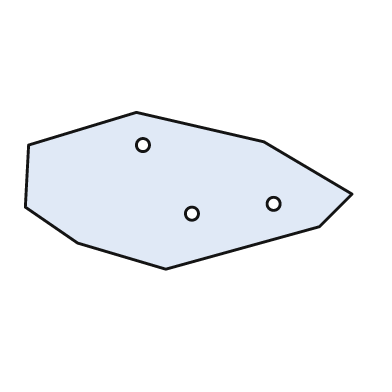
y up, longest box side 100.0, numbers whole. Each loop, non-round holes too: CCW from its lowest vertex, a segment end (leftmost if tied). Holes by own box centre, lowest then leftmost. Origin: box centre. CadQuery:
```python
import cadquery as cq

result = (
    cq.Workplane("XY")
    .moveTo(-7.0, -24.0)
    .lineTo(40.0, -11.0)
    .lineTo(50.0, -1.0)
    .lineTo(23.0, 15.0)
    .lineTo(-16.0, 24.0)
    .lineTo(-49.0, 14.0)
    .lineTo(-50.0, -5.0)
    .lineTo(-34.0, -16.0)
    .close()
    .moveTo(1.0, -7.0)
    .circle(2.0)
    .moveTo(26.0, -4.0)
    .circle(2.0)
    .moveTo(-14.0, 14.0)
    .circle(2.0)
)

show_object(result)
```